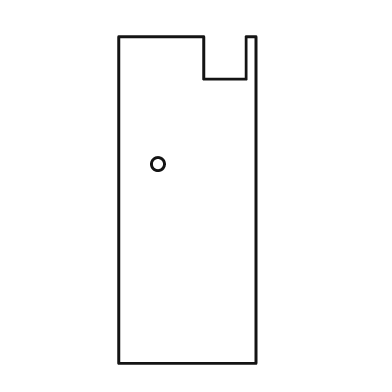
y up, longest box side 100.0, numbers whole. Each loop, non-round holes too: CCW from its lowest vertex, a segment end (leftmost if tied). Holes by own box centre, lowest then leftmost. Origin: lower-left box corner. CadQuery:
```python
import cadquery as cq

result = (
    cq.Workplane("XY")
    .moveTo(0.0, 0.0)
    .lineTo(42.0, 0.0)
    .lineTo(42.0, 100.0)
    .lineTo(39.0, 100.0)
    .lineTo(39.0, 87.0)
    .lineTo(26.0, 87.0)
    .lineTo(26.0, 100.0)
    .lineTo(0.0, 100.0)
    .close()
    .moveTo(12.0, 61.0)
    .circle(2.0)
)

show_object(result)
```